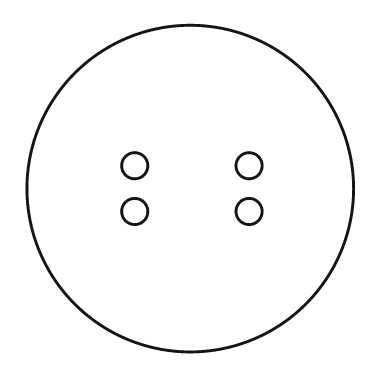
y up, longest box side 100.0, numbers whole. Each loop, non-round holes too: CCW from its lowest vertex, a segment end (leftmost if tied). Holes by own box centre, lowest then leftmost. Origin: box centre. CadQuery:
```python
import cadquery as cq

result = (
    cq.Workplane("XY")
    .moveTo(0.0, 0.0)
    .circle(50.0)
    .moveTo(-17.0, -7.0)
    .circle(4.0)
    .moveTo(18.0, -7.0)
    .circle(4.0)
    .moveTo(-17.0, 7.0)
    .circle(4.0)
    .moveTo(18.0, 7.0)
    .circle(4.0)
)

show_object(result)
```